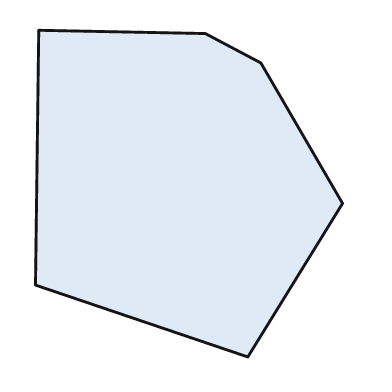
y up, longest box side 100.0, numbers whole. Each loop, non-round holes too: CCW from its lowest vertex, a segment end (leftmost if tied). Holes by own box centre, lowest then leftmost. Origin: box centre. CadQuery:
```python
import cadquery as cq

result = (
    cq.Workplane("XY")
    .moveTo(18.0, -50.0)
    .lineTo(47.0, -3.0)
    .lineTo(22.0, 40.0)
    .lineTo(5.0, 49.0)
    .lineTo(-46.0, 50.0)
    .lineTo(-47.0, -28.0)
    .close()
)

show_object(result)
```